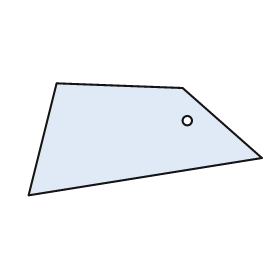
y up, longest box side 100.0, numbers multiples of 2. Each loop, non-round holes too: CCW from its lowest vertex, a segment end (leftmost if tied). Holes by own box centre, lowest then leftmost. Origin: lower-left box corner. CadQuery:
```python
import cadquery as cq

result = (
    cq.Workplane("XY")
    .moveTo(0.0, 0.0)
    .lineTo(100.0, 16.0)
    .lineTo(66.0, 46.0)
    .lineTo(12.0, 48.0)
    .close()
    .moveTo(68.0, 32.0)
    .circle(2.0)
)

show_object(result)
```